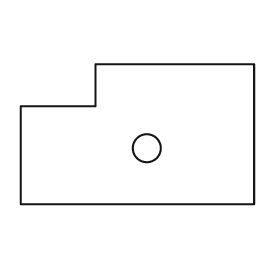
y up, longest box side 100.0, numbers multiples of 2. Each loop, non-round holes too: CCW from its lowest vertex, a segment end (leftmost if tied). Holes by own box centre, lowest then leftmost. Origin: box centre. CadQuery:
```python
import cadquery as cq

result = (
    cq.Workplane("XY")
    .moveTo(-50.0, -30.0)
    .lineTo(50.0, -30.0)
    .lineTo(50.0, 30.0)
    .lineTo(-18.0, 30.0)
    .lineTo(-18.0, 12.0)
    .lineTo(-50.0, 12.0)
    .close()
    .moveTo(4.0, -6.0)
    .circle(6.0)
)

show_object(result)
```